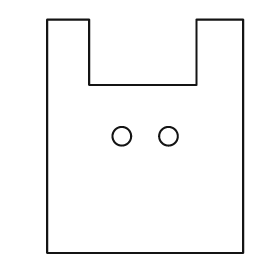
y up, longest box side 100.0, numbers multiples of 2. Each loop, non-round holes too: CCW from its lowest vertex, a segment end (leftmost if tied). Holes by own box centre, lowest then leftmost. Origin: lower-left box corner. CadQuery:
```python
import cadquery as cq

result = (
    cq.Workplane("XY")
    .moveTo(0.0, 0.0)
    .lineTo(84.0, 0.0)
    .lineTo(84.0, 100.0)
    .lineTo(64.0, 100.0)
    .lineTo(64.0, 72.0)
    .lineTo(18.0, 72.0)
    .lineTo(18.0, 100.0)
    .lineTo(0.0, 100.0)
    .close()
    .moveTo(32.0, 50.0)
    .circle(4.0)
    .moveTo(52.0, 50.0)
    .circle(4.0)
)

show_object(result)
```